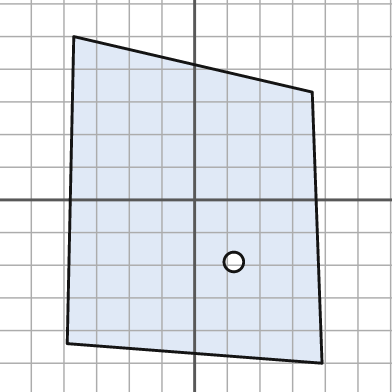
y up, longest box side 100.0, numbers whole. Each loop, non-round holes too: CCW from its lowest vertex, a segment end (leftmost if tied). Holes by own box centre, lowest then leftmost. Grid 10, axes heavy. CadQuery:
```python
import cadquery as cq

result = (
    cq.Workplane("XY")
    .moveTo(39.0, -50.0)
    .lineTo(36.0, 33.0)
    .lineTo(-37.0, 50.0)
    .lineTo(-39.0, -44.0)
    .close()
    .moveTo(12.0, -19.0)
    .circle(3.0)
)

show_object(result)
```